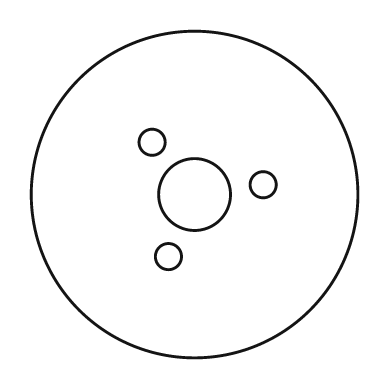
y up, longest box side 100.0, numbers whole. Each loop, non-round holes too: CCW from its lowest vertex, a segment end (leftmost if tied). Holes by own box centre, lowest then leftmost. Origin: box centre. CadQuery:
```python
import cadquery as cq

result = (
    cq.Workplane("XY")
    .moveTo(0.0, 0.0)
    .circle(50.0)
    .moveTo(-8.0, -19.0)
    .circle(4.0)
    .moveTo(0.0, 0.0)
    .circle(11.0)
    .moveTo(21.0, 3.0)
    .circle(4.0)
    .moveTo(-13.0, 16.0)
    .circle(4.0)
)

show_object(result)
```